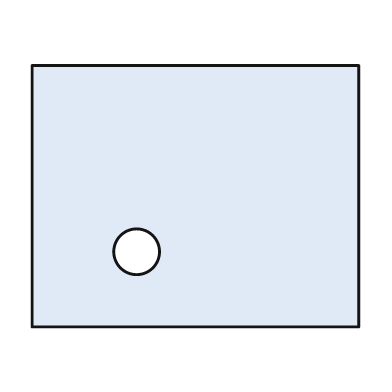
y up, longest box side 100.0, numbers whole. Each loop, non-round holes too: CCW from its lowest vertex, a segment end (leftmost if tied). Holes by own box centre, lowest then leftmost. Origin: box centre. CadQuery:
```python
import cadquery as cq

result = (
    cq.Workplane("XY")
    .moveTo(-50.0, -40.0)
    .lineTo(50.0, -40.0)
    .lineTo(50.0, 40.0)
    .lineTo(-50.0, 40.0)
    .close()
    .moveTo(-18.0, -17.0)
    .circle(7.0)
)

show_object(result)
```